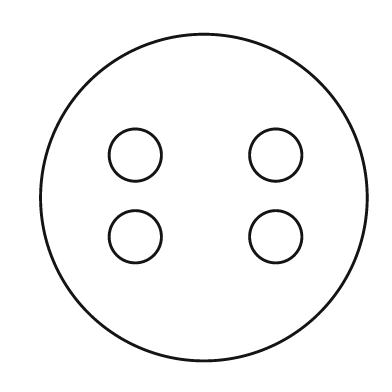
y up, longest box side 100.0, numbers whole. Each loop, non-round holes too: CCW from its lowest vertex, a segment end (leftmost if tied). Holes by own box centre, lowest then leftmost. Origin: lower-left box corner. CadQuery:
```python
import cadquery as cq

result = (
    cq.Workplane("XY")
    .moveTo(50.0, 50.0)
    .circle(50.0)
    .moveTo(29.0, 38.0)
    .circle(8.0)
    .moveTo(72.0, 38.0)
    .circle(8.0)
    .moveTo(29.0, 63.0)
    .circle(8.0)
    .moveTo(72.0, 63.0)
    .circle(8.0)
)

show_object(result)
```